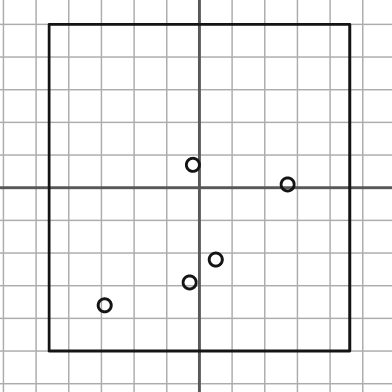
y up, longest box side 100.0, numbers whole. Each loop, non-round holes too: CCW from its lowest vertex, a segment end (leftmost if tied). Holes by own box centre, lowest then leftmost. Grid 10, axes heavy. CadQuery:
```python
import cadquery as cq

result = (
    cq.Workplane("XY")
    .moveTo(-46.0, -50.0)
    .lineTo(46.0, -50.0)
    .lineTo(46.0, 50.0)
    .lineTo(-46.0, 50.0)
    .close()
    .moveTo(-29.0, -36.0)
    .circle(2.0)
    .moveTo(-3.0, -29.0)
    .circle(2.0)
    .moveTo(5.0, -22.0)
    .circle(2.0)
    .moveTo(27.0, 1.0)
    .circle(2.0)
    .moveTo(-2.0, 7.0)
    .circle(2.0)
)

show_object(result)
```